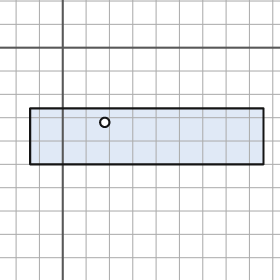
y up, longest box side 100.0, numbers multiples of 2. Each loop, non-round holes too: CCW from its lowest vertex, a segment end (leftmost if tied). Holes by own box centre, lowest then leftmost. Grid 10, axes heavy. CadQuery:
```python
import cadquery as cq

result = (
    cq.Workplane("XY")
    .moveTo(-14.0, -50.0)
    .lineTo(86.0, -50.0)
    .lineTo(86.0, -26.0)
    .lineTo(-14.0, -26.0)
    .close()
    .moveTo(18.0, -32.0)
    .circle(2.0)
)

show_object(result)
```